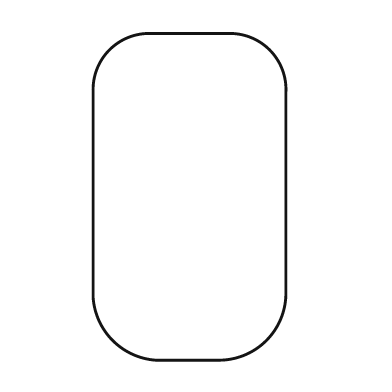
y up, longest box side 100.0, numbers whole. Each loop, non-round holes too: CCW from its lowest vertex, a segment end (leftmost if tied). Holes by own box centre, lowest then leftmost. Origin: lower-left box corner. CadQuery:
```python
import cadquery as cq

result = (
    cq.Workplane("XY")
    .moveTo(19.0, 0.0)
    .lineTo(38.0, 0.0)
    .threePointArc((53.0, 6.0), (59.0, 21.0))
    .lineTo(59.0, 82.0)
    .threePointArc((54.0, 95.0), (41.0, 100.0))
    .lineTo(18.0, 100.0)
    .threePointArc((5.0, 95.0), (0.0, 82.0))
    .lineTo(0.0, 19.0)
    .threePointArc((6.0, 6.0), (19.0, 0.0))
    .close()
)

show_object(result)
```